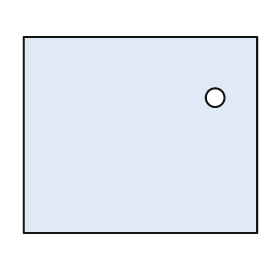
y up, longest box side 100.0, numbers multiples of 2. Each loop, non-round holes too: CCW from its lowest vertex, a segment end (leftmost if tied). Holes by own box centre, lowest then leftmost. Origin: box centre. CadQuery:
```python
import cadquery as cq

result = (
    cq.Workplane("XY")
    .moveTo(-50.0, -42.0)
    .lineTo(50.0, -42.0)
    .lineTo(50.0, 42.0)
    .lineTo(-50.0, 42.0)
    .close()
    .moveTo(32.0, 16.0)
    .circle(4.0)
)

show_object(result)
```